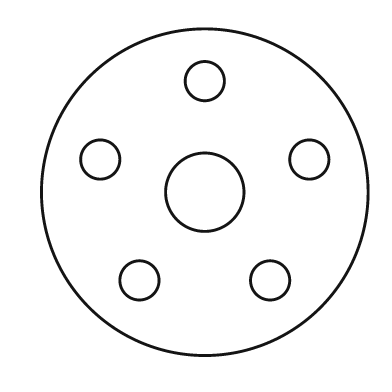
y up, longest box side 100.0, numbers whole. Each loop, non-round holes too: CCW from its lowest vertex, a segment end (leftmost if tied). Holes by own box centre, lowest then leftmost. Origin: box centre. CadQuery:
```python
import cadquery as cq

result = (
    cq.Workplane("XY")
    .moveTo(0.0, 0.0)
    .circle(50.0)
    .moveTo(-20.0, -27.0)
    .circle(6.0)
    .moveTo(20.0, -27.0)
    .circle(6.0)
    .moveTo(0.0, 0.0)
    .circle(12.0)
    .moveTo(-32.0, 10.0)
    .circle(6.0)
    .moveTo(32.0, 10.0)
    .circle(6.0)
    .moveTo(0.0, 34.0)
    .circle(6.0)
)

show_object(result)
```